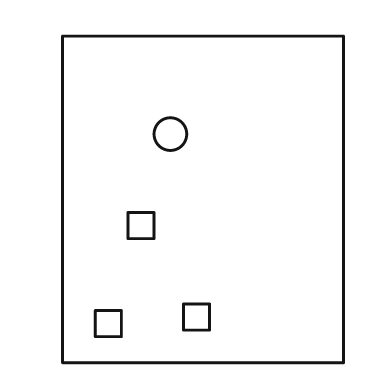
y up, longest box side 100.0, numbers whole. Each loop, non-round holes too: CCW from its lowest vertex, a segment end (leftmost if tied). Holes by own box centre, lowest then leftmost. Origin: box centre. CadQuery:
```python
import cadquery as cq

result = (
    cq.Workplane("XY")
    .moveTo(-43.0, -50.0)
    .lineTo(43.0, -50.0)
    .lineTo(43.0, 50.0)
    .lineTo(-43.0, 50.0)
    .close()
    .moveTo(-33.0, -42.0)
    .lineTo(-25.0, -42.0)
    .lineTo(-25.0, -34.0)
    .lineTo(-33.0, -34.0)
    .close()
    .moveTo(-6.0, -40.0)
    .lineTo(2.0, -40.0)
    .lineTo(2.0, -32.0)
    .lineTo(-6.0, -32.0)
    .close()
    .moveTo(-23.0, -12.0)
    .lineTo(-15.0, -12.0)
    .lineTo(-15.0, -4.0)
    .lineTo(-23.0, -4.0)
    .close()
    .moveTo(-10.0, 20.0)
    .circle(5.0)
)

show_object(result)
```